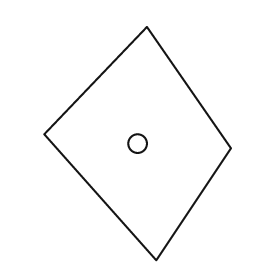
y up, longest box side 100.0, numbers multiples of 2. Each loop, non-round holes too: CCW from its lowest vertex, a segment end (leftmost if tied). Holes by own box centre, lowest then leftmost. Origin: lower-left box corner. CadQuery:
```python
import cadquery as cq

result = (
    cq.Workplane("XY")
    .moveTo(48.0, 0.0)
    .lineTo(80.0, 48.0)
    .lineTo(44.0, 100.0)
    .lineTo(0.0, 54.0)
    .close()
    .moveTo(40.0, 50.0)
    .circle(4.0)
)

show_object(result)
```